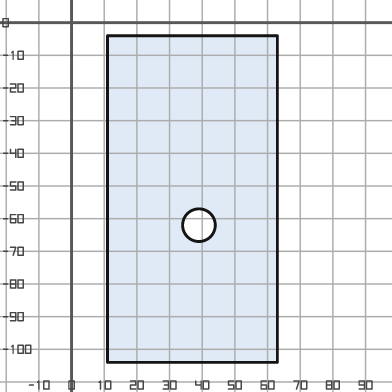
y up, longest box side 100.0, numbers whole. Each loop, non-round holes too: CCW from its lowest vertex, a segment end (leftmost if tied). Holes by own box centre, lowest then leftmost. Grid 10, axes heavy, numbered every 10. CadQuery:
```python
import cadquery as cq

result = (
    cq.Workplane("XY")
    .moveTo(11.0, -104.0)
    .lineTo(63.0, -104.0)
    .lineTo(63.0, -4.0)
    .lineTo(11.0, -4.0)
    .close()
    .moveTo(39.0, -62.0)
    .circle(5.0)
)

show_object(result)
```